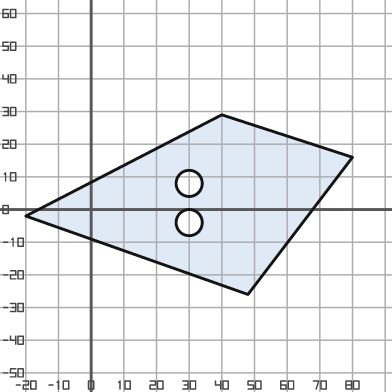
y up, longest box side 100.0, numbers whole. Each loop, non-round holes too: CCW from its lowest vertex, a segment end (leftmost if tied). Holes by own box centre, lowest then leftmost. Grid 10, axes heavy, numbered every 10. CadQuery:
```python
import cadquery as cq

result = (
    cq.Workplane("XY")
    .moveTo(48.0, -26.0)
    .lineTo(80.0, 16.0)
    .lineTo(40.0, 29.0)
    .lineTo(-20.0, -2.0)
    .close()
    .moveTo(30.0, -4.0)
    .circle(4.0)
    .moveTo(30.0, 8.0)
    .circle(4.0)
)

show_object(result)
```